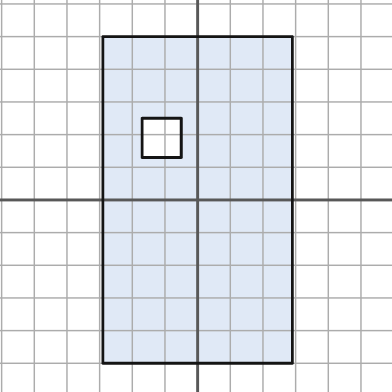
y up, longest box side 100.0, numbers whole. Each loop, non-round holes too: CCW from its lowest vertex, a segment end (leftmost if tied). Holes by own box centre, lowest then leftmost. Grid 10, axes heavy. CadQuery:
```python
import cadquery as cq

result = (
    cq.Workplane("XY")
    .moveTo(-29.0, -50.0)
    .lineTo(29.0, -50.0)
    .lineTo(29.0, 50.0)
    .lineTo(-29.0, 50.0)
    .close()
    .moveTo(-17.0, 13.0)
    .lineTo(-5.0, 13.0)
    .lineTo(-5.0, 25.0)
    .lineTo(-17.0, 25.0)
    .close()
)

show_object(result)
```